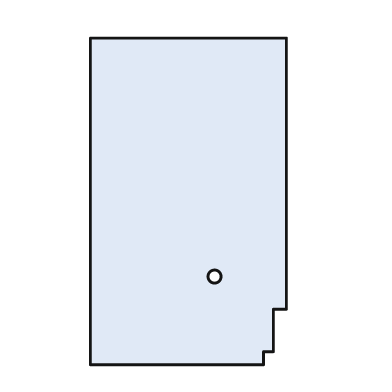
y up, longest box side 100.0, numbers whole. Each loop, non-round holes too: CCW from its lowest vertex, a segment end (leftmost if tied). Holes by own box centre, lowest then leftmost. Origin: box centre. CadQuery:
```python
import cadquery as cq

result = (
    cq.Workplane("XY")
    .moveTo(-30.0, -50.0)
    .lineTo(23.0, -50.0)
    .lineTo(23.0, -46.0)
    .lineTo(26.0, -46.0)
    .lineTo(26.0, -33.0)
    .lineTo(30.0, -33.0)
    .lineTo(30.0, 50.0)
    .lineTo(-30.0, 50.0)
    .close()
    .moveTo(8.0, -23.0)
    .circle(2.0)
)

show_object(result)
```